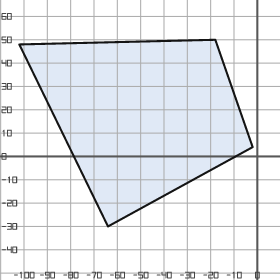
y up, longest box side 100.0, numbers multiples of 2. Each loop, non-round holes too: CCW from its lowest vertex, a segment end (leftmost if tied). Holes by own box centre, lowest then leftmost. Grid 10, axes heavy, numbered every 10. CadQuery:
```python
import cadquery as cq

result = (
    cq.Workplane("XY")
    .moveTo(-64.0, -30.0)
    .lineTo(-2.0, 4.0)
    .lineTo(-18.0, 50.0)
    .lineTo(-102.0, 48.0)
    .close()
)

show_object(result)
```